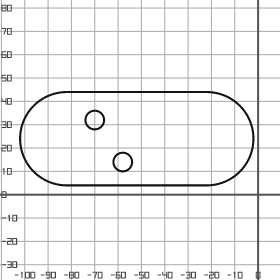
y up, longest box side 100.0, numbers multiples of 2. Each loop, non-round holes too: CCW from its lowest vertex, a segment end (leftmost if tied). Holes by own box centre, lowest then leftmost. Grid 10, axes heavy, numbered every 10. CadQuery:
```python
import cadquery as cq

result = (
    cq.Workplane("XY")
    .moveTo(-82.0, 4.0)
    .lineTo(-22.0, 4.0)
    .threePointArc((-2.0, 24.0), (-22.0, 44.0))
    .lineTo(-82.0, 44.0)
    .threePointArc((-102.0, 24.0), (-82.0, 4.0))
    .close()
    .moveTo(-58.0, 14.0)
    .circle(4.0)
    .moveTo(-70.0, 32.0)
    .circle(4.0)
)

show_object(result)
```